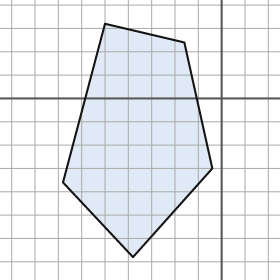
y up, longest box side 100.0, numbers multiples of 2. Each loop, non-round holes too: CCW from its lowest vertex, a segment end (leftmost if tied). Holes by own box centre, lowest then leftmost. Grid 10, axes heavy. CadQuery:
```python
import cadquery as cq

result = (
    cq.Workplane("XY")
    .moveTo(-38.0, -68.0)
    .lineTo(-4.0, -30.0)
    .lineTo(-16.0, 24.0)
    .lineTo(-50.0, 32.0)
    .lineTo(-68.0, -36.0)
    .close()
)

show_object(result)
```